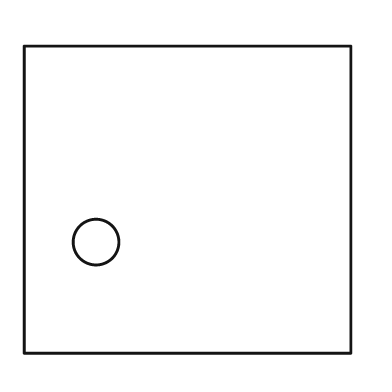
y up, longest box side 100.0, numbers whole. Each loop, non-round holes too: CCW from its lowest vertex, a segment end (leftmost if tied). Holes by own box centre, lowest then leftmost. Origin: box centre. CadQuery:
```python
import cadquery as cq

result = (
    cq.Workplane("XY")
    .moveTo(-50.0, -47.0)
    .lineTo(50.0, -47.0)
    .lineTo(50.0, 47.0)
    .lineTo(-50.0, 47.0)
    .close()
    .moveTo(-28.0, -13.0)
    .circle(7.0)
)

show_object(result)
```